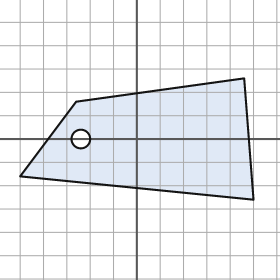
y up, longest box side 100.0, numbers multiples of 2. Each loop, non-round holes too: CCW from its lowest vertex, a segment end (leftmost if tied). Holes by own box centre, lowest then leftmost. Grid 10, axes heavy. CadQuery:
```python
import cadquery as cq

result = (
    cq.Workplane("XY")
    .moveTo(50.0, -26.0)
    .lineTo(46.0, 26.0)
    .lineTo(-26.0, 16.0)
    .lineTo(-50.0, -16.0)
    .close()
    .moveTo(-24.0, 0.0)
    .circle(4.0)
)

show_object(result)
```